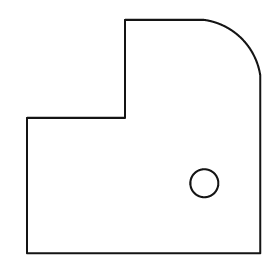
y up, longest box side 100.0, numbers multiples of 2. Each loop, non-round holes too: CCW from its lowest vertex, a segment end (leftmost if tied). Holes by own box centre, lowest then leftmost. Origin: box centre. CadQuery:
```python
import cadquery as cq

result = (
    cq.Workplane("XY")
    .moveTo(-50.0, -50.0)
    .lineTo(50.0, -50.0)
    .lineTo(50.0, 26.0)
    .threePointArc((42.0, 42.0), (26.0, 50.0))
    .lineTo(-8.0, 50.0)
    .lineTo(-8.0, 8.0)
    .lineTo(-50.0, 8.0)
    .close()
    .moveTo(26.0, -20.0)
    .circle(6.0)
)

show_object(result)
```